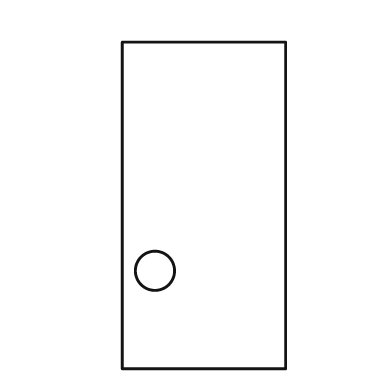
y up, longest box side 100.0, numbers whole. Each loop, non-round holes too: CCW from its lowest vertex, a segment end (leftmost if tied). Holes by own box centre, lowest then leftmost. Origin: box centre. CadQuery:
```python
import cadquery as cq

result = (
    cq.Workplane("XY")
    .moveTo(-25.0, -50.0)
    .lineTo(25.0, -50.0)
    .lineTo(25.0, 50.0)
    .lineTo(-25.0, 50.0)
    .close()
    .moveTo(-15.0, -20.0)
    .circle(6.0)
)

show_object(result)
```